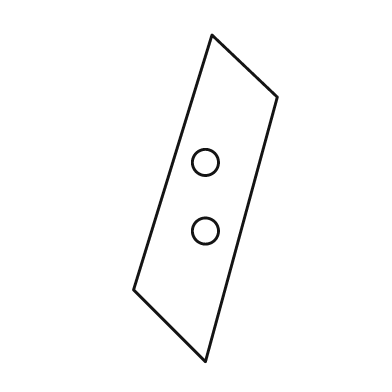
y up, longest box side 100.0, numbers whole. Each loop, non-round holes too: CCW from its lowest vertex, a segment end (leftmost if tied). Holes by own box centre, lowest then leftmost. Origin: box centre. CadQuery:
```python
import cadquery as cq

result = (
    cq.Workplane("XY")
    .moveTo(0.0, -50.0)
    .lineTo(22.0, 31.0)
    .lineTo(2.0, 50.0)
    .lineTo(-22.0, -28.0)
    .close()
    .moveTo(0.0, -10.0)
    .circle(4.0)
    .moveTo(0.0, 11.0)
    .circle(4.0)
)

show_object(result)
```